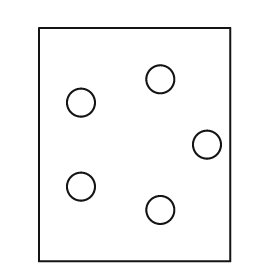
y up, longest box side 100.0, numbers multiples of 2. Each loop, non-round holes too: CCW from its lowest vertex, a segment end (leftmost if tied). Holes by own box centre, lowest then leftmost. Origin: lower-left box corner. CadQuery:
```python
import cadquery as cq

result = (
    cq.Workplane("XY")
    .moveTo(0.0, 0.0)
    .lineTo(82.0, 0.0)
    .lineTo(82.0, 100.0)
    .lineTo(0.0, 100.0)
    .close()
    .moveTo(52.0, 22.0)
    .circle(6.0)
    .moveTo(18.0, 32.0)
    .circle(6.0)
    .moveTo(72.0, 50.0)
    .circle(6.0)
    .moveTo(18.0, 68.0)
    .circle(6.0)
    .moveTo(52.0, 78.0)
    .circle(6.0)
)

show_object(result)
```